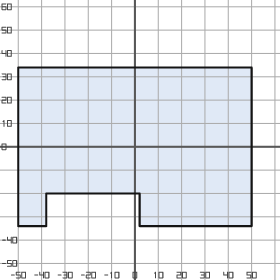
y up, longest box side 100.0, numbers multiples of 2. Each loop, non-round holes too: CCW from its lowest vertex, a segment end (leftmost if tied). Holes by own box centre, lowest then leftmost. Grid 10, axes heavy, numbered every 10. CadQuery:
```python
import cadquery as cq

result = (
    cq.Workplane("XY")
    .moveTo(-50.0, -34.0)
    .lineTo(-38.0, -34.0)
    .lineTo(-38.0, -20.0)
    .lineTo(2.0, -20.0)
    .lineTo(2.0, -34.0)
    .lineTo(50.0, -34.0)
    .lineTo(50.0, 34.0)
    .lineTo(-50.0, 34.0)
    .close()
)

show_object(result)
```